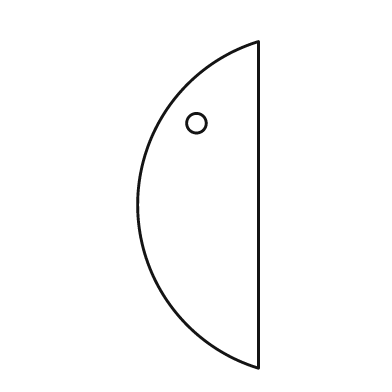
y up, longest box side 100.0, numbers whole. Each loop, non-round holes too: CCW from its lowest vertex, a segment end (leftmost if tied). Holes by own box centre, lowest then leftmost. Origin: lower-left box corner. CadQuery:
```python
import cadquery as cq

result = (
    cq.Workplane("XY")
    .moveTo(37.0, 0.0)
    .lineTo(37.0, 100.0)
    .threePointArc((0.0, 50.0), (37.0, 0.0))
    .close()
    .moveTo(18.0, 75.0)
    .circle(3.0)
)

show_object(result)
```